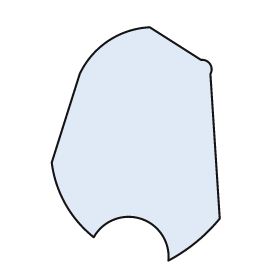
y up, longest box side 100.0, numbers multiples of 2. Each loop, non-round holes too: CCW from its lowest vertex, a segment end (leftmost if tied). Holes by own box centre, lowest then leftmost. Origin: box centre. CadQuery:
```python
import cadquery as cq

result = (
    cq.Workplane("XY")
    .moveTo(14.0, -50.0)
    .threePointArc((26.0, -42.0), (36.0, -32.0))
    .lineTo(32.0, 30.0)
    .threePointArc((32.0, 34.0), (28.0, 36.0))
    .lineTo(6.0, 50.0)
    .threePointArc((-12.0, 44.0), (-24.0, 30.0))
    .lineTo(-36.0, -8.0)
    .threePointArc((-30.0, -26.0), (-18.0, -40.0))
    .threePointArc((2.0, -32.0), (14.0, -50.0))
    .close()
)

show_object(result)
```